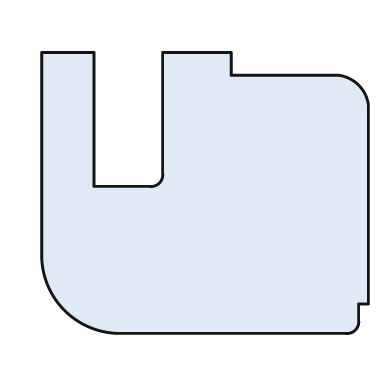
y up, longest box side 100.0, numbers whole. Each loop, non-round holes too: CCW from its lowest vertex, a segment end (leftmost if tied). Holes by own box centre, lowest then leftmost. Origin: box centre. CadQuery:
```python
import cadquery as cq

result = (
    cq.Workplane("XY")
    .moveTo(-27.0, -43.0)
    .lineTo(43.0, -43.0)
    .threePointArc((46.0, -42.0), (47.0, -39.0))
    .lineTo(47.0, -34.0)
    .lineTo(50.0, -34.0)
    .lineTo(50.0, 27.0)
    .threePointArc((47.0, 33.0), (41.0, 36.0))
    .lineTo(8.0, 36.0)
    .lineTo(8.0, 43.0)
    .lineTo(-13.0, 43.0)
    .lineTo(-13.0, 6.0)
    .threePointArc((-14.0, 3.0), (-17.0, 2.0))
    .lineTo(-34.0, 2.0)
    .lineTo(-34.0, 43.0)
    .lineTo(-50.0, 43.0)
    .lineTo(-50.0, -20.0)
    .threePointArc((-43.0, -36.0), (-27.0, -43.0))
    .close()
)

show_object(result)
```